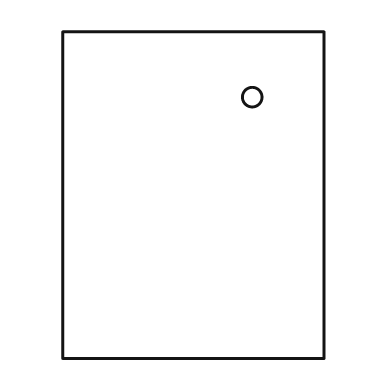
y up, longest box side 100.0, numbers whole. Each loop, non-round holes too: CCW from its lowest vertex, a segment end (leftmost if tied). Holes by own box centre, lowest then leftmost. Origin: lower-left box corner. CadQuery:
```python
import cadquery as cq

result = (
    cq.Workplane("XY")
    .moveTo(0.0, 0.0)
    .lineTo(80.0, 0.0)
    .lineTo(80.0, 100.0)
    .lineTo(0.0, 100.0)
    .close()
    .moveTo(58.0, 80.0)
    .circle(3.0)
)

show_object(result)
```